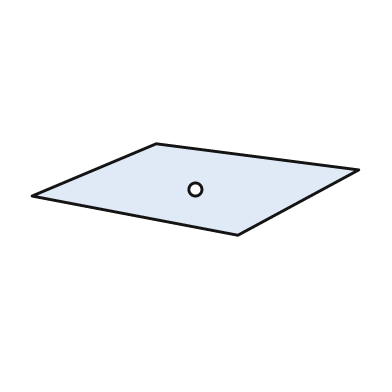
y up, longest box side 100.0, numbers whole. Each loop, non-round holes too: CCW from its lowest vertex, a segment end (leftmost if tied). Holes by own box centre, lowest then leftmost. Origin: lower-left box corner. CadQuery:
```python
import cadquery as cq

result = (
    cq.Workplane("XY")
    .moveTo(63.0, 0.0)
    .lineTo(100.0, 20.0)
    .lineTo(38.0, 28.0)
    .lineTo(0.0, 12.0)
    .close()
    .moveTo(50.0, 14.0)
    .circle(2.0)
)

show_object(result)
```